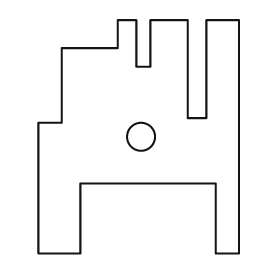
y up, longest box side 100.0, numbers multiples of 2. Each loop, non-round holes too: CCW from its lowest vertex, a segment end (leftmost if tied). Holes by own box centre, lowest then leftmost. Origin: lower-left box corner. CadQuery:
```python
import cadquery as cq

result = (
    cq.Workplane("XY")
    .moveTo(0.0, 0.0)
    .lineTo(18.0, 0.0)
    .lineTo(18.0, 30.0)
    .lineTo(76.0, 30.0)
    .lineTo(76.0, 0.0)
    .lineTo(86.0, 0.0)
    .lineTo(86.0, 100.0)
    .lineTo(72.0, 100.0)
    .lineTo(72.0, 58.0)
    .lineTo(64.0, 58.0)
    .lineTo(64.0, 100.0)
    .lineTo(48.0, 100.0)
    .lineTo(48.0, 80.0)
    .lineTo(42.0, 80.0)
    .lineTo(42.0, 100.0)
    .lineTo(34.0, 100.0)
    .lineTo(34.0, 88.0)
    .lineTo(10.0, 88.0)
    .lineTo(10.0, 56.0)
    .lineTo(0.0, 56.0)
    .close()
    .moveTo(44.0, 50.0)
    .circle(6.0)
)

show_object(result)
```